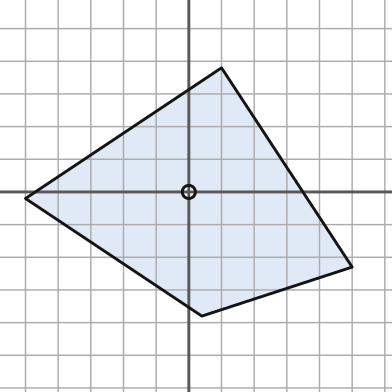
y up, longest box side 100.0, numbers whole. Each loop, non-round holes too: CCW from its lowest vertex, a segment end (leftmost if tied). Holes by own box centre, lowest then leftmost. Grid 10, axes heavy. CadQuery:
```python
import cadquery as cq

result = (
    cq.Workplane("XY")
    .moveTo(4.0, -38.0)
    .lineTo(50.0, -23.0)
    .lineTo(10.0, 38.0)
    .lineTo(-50.0, -2.0)
    .close()
    .moveTo(0.0, 0.0)
    .circle(2.0)
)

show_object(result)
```